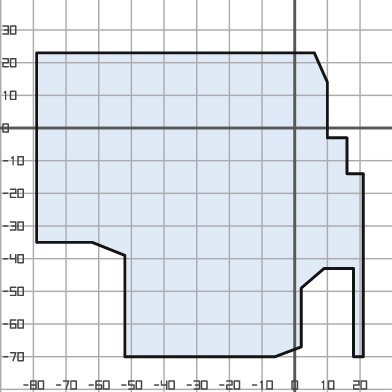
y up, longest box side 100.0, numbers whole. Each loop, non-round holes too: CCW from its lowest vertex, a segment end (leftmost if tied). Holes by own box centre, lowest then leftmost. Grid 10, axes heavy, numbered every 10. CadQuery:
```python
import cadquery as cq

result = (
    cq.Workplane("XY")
    .moveTo(-52.0, -70.0)
    .lineTo(-6.0, -70.0)
    .lineTo(2.0, -67.0)
    .lineTo(2.0, -49.0)
    .lineTo(9.0, -43.0)
    .lineTo(18.0, -43.0)
    .lineTo(18.0, -70.0)
    .lineTo(21.0, -70.0)
    .lineTo(21.0, -14.0)
    .lineTo(16.0, -14.0)
    .lineTo(16.0, -3.0)
    .lineTo(10.0, -3.0)
    .lineTo(10.0, 14.0)
    .lineTo(6.0, 23.0)
    .lineTo(-79.0, 23.0)
    .lineTo(-79.0, -35.0)
    .lineTo(-62.0, -35.0)
    .lineTo(-52.0, -39.0)
    .close()
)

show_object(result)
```